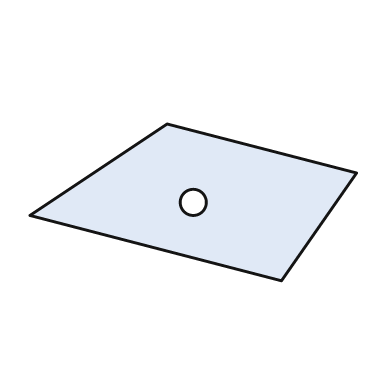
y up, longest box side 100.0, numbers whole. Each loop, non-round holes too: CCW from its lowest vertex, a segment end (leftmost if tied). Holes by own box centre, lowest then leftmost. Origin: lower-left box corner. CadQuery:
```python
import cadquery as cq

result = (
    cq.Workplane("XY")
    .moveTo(77.0, 0.0)
    .lineTo(100.0, 33.0)
    .lineTo(42.0, 48.0)
    .lineTo(0.0, 20.0)
    .close()
    .moveTo(50.0, 24.0)
    .circle(4.0)
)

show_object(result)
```